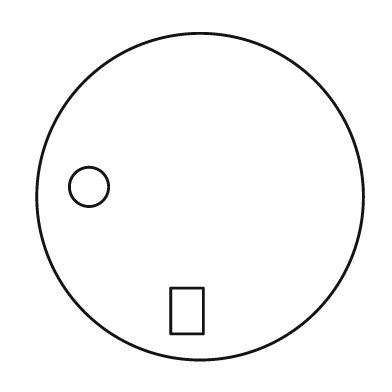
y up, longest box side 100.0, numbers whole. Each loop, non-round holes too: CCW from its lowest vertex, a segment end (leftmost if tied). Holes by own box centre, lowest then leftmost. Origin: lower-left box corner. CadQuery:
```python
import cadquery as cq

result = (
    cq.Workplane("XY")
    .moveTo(50.0, 50.0)
    .circle(50.0)
    .moveTo(41.0, 8.0)
    .lineTo(51.0, 8.0)
    .lineTo(51.0, 22.0)
    .lineTo(41.0, 22.0)
    .close()
    .moveTo(16.0, 53.0)
    .circle(6.0)
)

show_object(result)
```